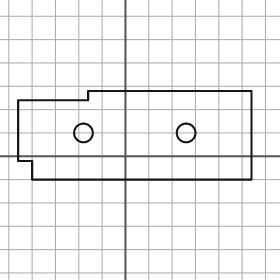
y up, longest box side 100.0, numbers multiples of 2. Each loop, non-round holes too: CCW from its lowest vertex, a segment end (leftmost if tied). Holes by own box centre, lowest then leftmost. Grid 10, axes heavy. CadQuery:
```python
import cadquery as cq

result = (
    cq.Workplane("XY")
    .moveTo(-40.0, -10.0)
    .lineTo(54.0, -10.0)
    .lineTo(54.0, 28.0)
    .lineTo(-16.0, 28.0)
    .lineTo(-16.0, 24.0)
    .lineTo(-46.0, 24.0)
    .lineTo(-46.0, -2.0)
    .lineTo(-40.0, -2.0)
    .close()
    .moveTo(-18.0, 10.0)
    .circle(4.0)
    .moveTo(26.0, 10.0)
    .circle(4.0)
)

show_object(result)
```